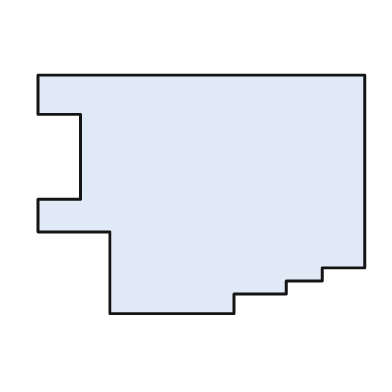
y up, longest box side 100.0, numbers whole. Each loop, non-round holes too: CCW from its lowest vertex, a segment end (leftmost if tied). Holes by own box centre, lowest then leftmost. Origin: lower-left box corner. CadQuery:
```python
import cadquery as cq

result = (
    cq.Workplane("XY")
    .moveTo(22.0, 0.0)
    .lineTo(60.0, 0.0)
    .lineTo(60.0, 6.0)
    .lineTo(76.0, 6.0)
    .lineTo(76.0, 10.0)
    .lineTo(87.0, 10.0)
    .lineTo(87.0, 14.0)
    .lineTo(100.0, 14.0)
    .lineTo(100.0, 73.0)
    .lineTo(0.0, 73.0)
    .lineTo(0.0, 61.0)
    .lineTo(13.0, 61.0)
    .lineTo(13.0, 35.0)
    .lineTo(0.0, 35.0)
    .lineTo(0.0, 25.0)
    .lineTo(22.0, 25.0)
    .close()
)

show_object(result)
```